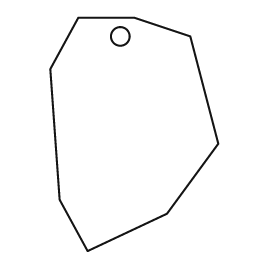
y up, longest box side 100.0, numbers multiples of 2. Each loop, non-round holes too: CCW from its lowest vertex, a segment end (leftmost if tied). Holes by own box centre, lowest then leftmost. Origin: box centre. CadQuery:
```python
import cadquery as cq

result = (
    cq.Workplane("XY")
    .moveTo(-20.0, -50.0)
    .lineTo(14.0, -34.0)
    .lineTo(36.0, -4.0)
    .lineTo(24.0, 42.0)
    .lineTo(0.0, 50.0)
    .lineTo(-24.0, 50.0)
    .lineTo(-36.0, 28.0)
    .lineTo(-32.0, -28.0)
    .close()
    .moveTo(-6.0, 42.0)
    .circle(4.0)
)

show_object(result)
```